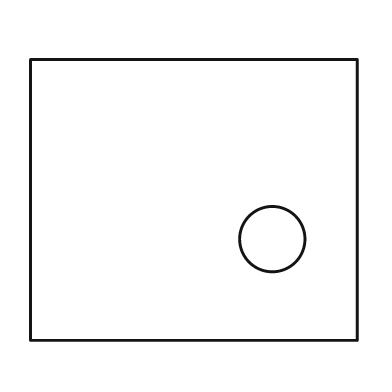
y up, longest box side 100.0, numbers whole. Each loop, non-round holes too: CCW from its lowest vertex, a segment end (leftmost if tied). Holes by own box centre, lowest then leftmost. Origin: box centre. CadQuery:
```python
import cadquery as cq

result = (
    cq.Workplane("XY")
    .moveTo(-50.0, -43.0)
    .lineTo(50.0, -43.0)
    .lineTo(50.0, 43.0)
    .lineTo(-50.0, 43.0)
    .close()
    .moveTo(24.0, -12.0)
    .circle(10.0)
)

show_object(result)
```